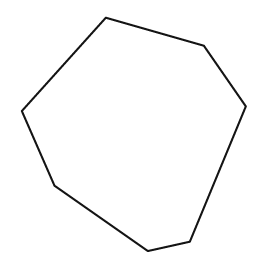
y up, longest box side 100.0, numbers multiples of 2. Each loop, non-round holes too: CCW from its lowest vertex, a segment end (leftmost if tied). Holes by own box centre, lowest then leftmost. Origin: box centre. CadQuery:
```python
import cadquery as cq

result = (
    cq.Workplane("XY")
    .moveTo(6.0, -50.0)
    .lineTo(24.0, -46.0)
    .lineTo(48.0, 12.0)
    .lineTo(30.0, 38.0)
    .lineTo(-12.0, 50.0)
    .lineTo(-48.0, 10.0)
    .lineTo(-34.0, -22.0)
    .close()
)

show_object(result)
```